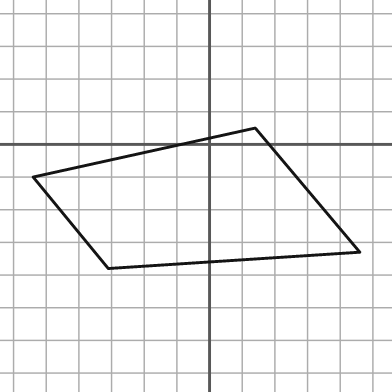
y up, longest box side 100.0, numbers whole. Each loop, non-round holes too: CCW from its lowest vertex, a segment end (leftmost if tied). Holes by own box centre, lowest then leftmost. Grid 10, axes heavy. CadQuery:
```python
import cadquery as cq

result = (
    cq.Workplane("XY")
    .moveTo(-31.0, -38.0)
    .lineTo(46.0, -33.0)
    .lineTo(14.0, 5.0)
    .lineTo(-54.0, -10.0)
    .close()
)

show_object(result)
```